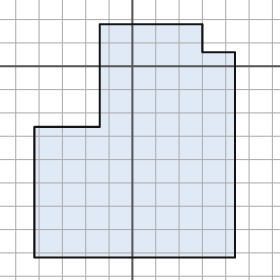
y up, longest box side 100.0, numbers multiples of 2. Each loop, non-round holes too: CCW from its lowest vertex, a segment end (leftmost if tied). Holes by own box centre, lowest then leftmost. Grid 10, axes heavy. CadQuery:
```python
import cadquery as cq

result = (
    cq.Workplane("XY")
    .moveTo(-42.0, -82.0)
    .lineTo(44.0, -82.0)
    .lineTo(44.0, 6.0)
    .lineTo(30.0, 6.0)
    .lineTo(30.0, 18.0)
    .lineTo(-14.0, 18.0)
    .lineTo(-14.0, -26.0)
    .lineTo(-42.0, -26.0)
    .close()
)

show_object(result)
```